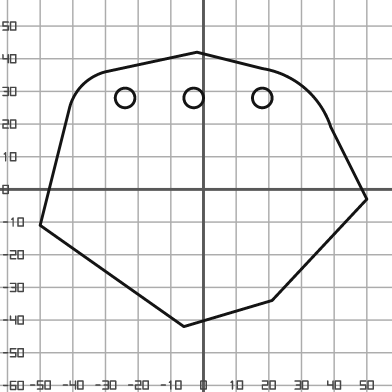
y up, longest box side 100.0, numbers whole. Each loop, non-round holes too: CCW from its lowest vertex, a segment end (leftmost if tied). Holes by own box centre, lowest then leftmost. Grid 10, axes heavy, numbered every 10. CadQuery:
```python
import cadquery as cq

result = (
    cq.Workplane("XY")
    .moveTo(-6.0, -42.0)
    .lineTo(21.0, -34.0)
    .lineTo(50.0, -3.0)
    .lineTo(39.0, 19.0)
    .threePointArc((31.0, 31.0), (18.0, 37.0))
    .lineTo(-2.0, 42.0)
    .lineTo(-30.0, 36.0)
    .threePointArc((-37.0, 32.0), (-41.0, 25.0))
    .lineTo(-50.0, -11.0)
    .close()
    .moveTo(-24.0, 28.0)
    .circle(3.0)
    .moveTo(-3.0, 28.0)
    .circle(3.0)
    .moveTo(18.0, 28.0)
    .circle(3.0)
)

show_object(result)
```